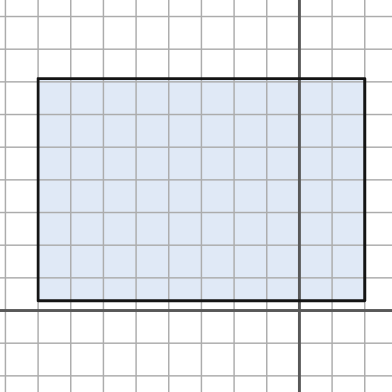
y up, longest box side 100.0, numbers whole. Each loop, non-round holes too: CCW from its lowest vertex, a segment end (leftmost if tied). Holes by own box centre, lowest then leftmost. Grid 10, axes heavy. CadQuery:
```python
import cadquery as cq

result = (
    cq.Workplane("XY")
    .moveTo(-80.0, 3.0)
    .lineTo(20.0, 3.0)
    .lineTo(20.0, 71.0)
    .lineTo(-80.0, 71.0)
    .close()
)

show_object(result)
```